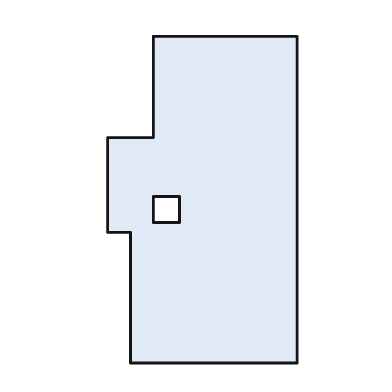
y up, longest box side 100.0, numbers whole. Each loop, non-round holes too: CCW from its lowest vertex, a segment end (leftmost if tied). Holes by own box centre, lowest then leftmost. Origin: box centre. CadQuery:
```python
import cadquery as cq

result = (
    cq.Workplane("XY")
    .moveTo(-22.0, -50.0)
    .lineTo(29.0, -50.0)
    .lineTo(29.0, 50.0)
    .lineTo(-15.0, 50.0)
    .lineTo(-15.0, 19.0)
    .lineTo(-29.0, 19.0)
    .lineTo(-29.0, -10.0)
    .lineTo(-22.0, -10.0)
    .close()
    .moveTo(-15.0, -7.0)
    .lineTo(-7.0, -7.0)
    .lineTo(-7.0, 1.0)
    .lineTo(-15.0, 1.0)
    .close()
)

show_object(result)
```